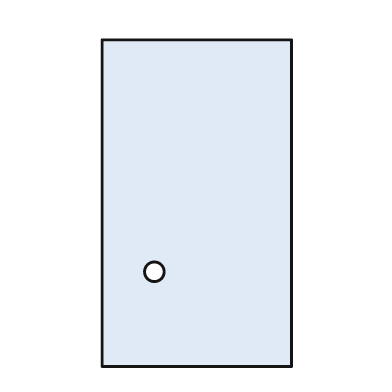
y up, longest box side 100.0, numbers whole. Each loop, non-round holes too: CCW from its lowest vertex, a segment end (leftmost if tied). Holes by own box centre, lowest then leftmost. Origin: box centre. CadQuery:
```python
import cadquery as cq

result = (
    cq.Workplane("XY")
    .moveTo(-29.0, -50.0)
    .lineTo(29.0, -50.0)
    .lineTo(29.0, 50.0)
    .lineTo(-29.0, 50.0)
    .close()
    .moveTo(-13.0, -21.0)
    .circle(3.0)
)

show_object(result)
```